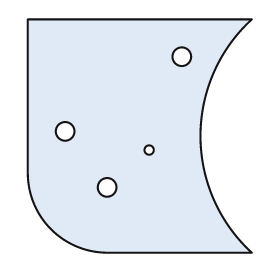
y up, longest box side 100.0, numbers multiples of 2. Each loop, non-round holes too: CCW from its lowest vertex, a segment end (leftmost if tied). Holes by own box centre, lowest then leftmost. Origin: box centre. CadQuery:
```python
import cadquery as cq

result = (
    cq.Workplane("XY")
    .moveTo(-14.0, -50.0)
    .lineTo(48.0, -50.0)
    .threePointArc((26.0, 0.0), (48.0, 50.0))
    .lineTo(-48.0, 50.0)
    .lineTo(-48.0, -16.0)
    .threePointArc((-38.0, -40.0), (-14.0, -50.0))
    .close()
    .moveTo(-14.0, -22.0)
    .circle(4.0)
    .moveTo(4.0, -6.0)
    .circle(2.0)
    .moveTo(-32.0, 2.0)
    .circle(4.0)
    .moveTo(18.0, 34.0)
    .circle(4.0)
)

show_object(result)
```